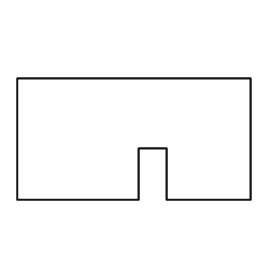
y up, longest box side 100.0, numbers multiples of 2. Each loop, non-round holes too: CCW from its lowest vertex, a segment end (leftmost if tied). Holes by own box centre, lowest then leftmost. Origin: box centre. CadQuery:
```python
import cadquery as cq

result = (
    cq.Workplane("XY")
    .moveTo(-50.0, -26.0)
    .lineTo(2.0, -26.0)
    .lineTo(2.0, -4.0)
    .lineTo(14.0, -4.0)
    .lineTo(14.0, -26.0)
    .lineTo(50.0, -26.0)
    .lineTo(50.0, 26.0)
    .lineTo(-50.0, 26.0)
    .close()
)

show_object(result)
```